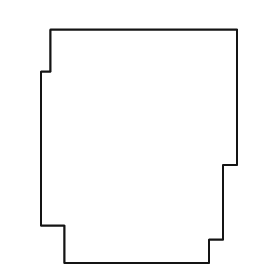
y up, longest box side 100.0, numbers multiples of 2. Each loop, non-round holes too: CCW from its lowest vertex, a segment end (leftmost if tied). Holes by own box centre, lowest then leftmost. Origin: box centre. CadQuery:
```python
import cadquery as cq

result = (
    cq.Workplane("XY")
    .moveTo(-32.0, -50.0)
    .lineTo(30.0, -50.0)
    .lineTo(30.0, -40.0)
    .lineTo(36.0, -40.0)
    .lineTo(36.0, -8.0)
    .lineTo(42.0, -8.0)
    .lineTo(42.0, 50.0)
    .lineTo(-38.0, 50.0)
    .lineTo(-38.0, 32.0)
    .lineTo(-42.0, 32.0)
    .lineTo(-42.0, -34.0)
    .lineTo(-32.0, -34.0)
    .close()
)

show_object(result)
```